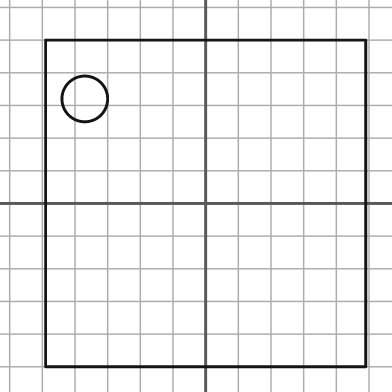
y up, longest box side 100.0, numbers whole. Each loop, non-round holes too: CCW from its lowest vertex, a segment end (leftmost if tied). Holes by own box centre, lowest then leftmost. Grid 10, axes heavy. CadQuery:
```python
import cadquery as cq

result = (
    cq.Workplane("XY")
    .moveTo(-49.0, -50.0)
    .lineTo(49.0, -50.0)
    .lineTo(49.0, 50.0)
    .lineTo(-49.0, 50.0)
    .close()
    .moveTo(-37.0, 32.0)
    .circle(7.0)
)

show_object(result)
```